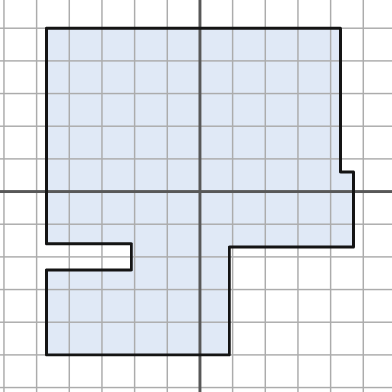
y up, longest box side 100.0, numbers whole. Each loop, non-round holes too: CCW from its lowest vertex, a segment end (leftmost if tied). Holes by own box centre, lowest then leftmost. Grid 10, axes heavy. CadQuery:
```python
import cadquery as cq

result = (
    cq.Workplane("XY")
    .moveTo(-47.0, -50.0)
    .lineTo(9.0, -50.0)
    .lineTo(9.0, -17.0)
    .lineTo(47.0, -17.0)
    .lineTo(47.0, 6.0)
    .lineTo(43.0, 6.0)
    .lineTo(43.0, 50.0)
    .lineTo(-47.0, 50.0)
    .lineTo(-47.0, -16.0)
    .lineTo(-21.0, -16.0)
    .lineTo(-21.0, -24.0)
    .lineTo(-47.0, -24.0)
    .close()
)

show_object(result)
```